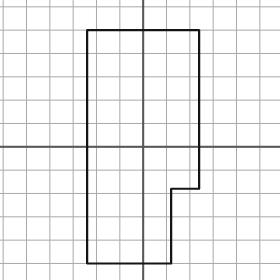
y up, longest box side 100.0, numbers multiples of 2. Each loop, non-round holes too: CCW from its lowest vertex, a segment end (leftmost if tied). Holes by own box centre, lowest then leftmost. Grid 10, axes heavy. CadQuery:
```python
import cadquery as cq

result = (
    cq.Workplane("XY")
    .moveTo(-24.0, -50.0)
    .lineTo(12.0, -50.0)
    .lineTo(12.0, -18.0)
    .lineTo(24.0, -18.0)
    .lineTo(24.0, 50.0)
    .lineTo(-24.0, 50.0)
    .close()
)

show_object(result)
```